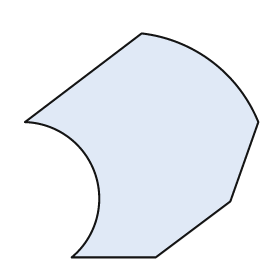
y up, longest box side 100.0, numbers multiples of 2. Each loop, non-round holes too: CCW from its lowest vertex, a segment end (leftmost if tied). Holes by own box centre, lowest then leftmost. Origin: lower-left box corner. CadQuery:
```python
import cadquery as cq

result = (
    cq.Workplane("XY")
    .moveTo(20.0, 0.0)
    .lineTo(56.0, 0.0)
    .lineTo(88.0, 24.0)
    .lineTo(100.0, 58.0)
    .threePointArc((80.0, 84.0), (50.0, 96.0))
    .lineTo(0.0, 58.0)
    .threePointArc((30.0, 36.0), (20.0, 0.0))
    .close()
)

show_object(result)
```